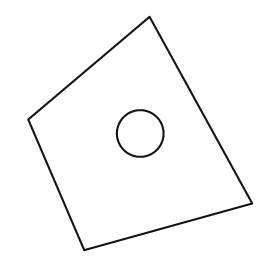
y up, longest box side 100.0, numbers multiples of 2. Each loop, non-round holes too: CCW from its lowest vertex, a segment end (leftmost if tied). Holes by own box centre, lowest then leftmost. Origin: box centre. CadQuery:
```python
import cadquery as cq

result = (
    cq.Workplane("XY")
    .moveTo(-24.0, -50.0)
    .lineTo(48.0, -30.0)
    .lineTo(4.0, 50.0)
    .lineTo(-48.0, 6.0)
    .close()
    .moveTo(0.0, 0.0)
    .circle(10.0)
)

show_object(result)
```